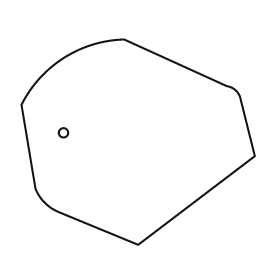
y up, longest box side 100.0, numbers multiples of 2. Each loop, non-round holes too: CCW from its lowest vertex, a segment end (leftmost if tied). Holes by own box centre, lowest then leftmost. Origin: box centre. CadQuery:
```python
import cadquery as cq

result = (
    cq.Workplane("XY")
    .moveTo(0.0, -44.0)
    .lineTo(50.0, -6.0)
    .lineTo(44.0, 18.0)
    .threePointArc((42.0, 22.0), (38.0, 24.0))
    .lineTo(-6.0, 44.0)
    .threePointArc((-32.0, 36.0), (-50.0, 16.0))
    .lineTo(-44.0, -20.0)
    .threePointArc((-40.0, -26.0), (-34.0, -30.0))
    .close()
    .moveTo(-32.0, 4.0)
    .circle(2.0)
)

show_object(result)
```